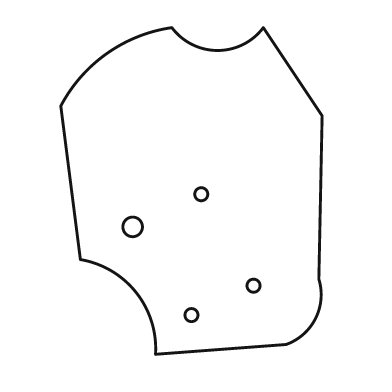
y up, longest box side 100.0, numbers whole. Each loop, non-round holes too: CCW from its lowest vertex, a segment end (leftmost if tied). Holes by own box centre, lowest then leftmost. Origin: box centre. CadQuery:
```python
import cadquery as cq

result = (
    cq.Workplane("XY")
    .moveTo(-11.0, -50.0)
    .lineTo(29.0, -47.0)
    .threePointArc((38.0, -39.0), (39.0, -27.0))
    .lineTo(40.0, 23.0)
    .lineTo(22.0, 50.0)
    .threePointArc((8.0, 43.0), (-6.0, 50.0))
    .threePointArc((-26.0, 42.0), (-40.0, 26.0))
    .lineTo(-34.0, -21.0)
    .threePointArc((-17.0, -31.0), (-11.0, -50.0))
    .close()
    .moveTo(0.0, -38.0)
    .circle(2.0)
    .moveTo(19.0, -29.0)
    .circle(2.0)
    .moveTo(-18.0, -11.0)
    .circle(3.0)
    .moveTo(3.0, -1.0)
    .circle(2.0)
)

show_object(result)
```